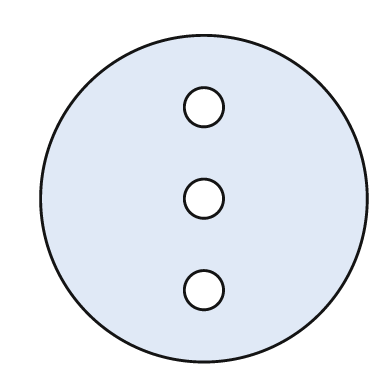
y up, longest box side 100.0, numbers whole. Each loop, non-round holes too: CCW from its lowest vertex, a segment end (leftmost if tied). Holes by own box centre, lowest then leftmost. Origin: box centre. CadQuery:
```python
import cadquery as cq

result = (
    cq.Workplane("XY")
    .moveTo(0.0, 0.0)
    .circle(50.0)
    .moveTo(0.0, -28.0)
    .circle(6.0)
    .moveTo(0.0, 0.0)
    .circle(6.0)
    .moveTo(0.0, 28.0)
    .circle(6.0)
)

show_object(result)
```